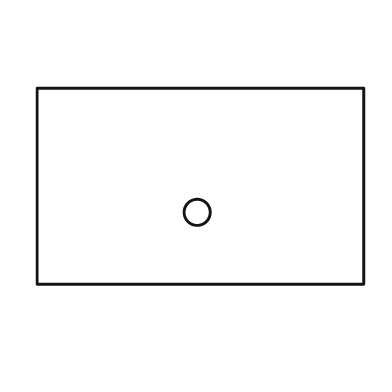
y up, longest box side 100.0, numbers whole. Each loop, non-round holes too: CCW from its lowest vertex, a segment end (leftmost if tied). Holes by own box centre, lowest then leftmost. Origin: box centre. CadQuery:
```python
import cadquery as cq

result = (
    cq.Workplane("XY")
    .moveTo(-50.0, -30.0)
    .lineTo(50.0, -30.0)
    .lineTo(50.0, 30.0)
    .lineTo(-50.0, 30.0)
    .close()
    .moveTo(-1.0, -8.0)
    .circle(4.0)
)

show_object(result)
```